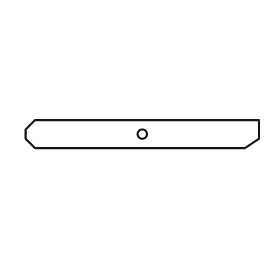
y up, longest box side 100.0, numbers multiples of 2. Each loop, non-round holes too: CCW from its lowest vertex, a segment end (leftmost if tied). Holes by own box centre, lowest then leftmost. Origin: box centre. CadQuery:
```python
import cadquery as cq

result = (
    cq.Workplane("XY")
    .moveTo(-46.0, -6.0)
    .lineTo(44.0, -6.0)
    .lineTo(50.0, -2.0)
    .lineTo(50.0, 6.0)
    .lineTo(-46.0, 6.0)
    .lineTo(-50.0, 2.0)
    .lineTo(-50.0, -2.0)
    .close()
    .moveTo(0.0, 0.0)
    .circle(2.0)
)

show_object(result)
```